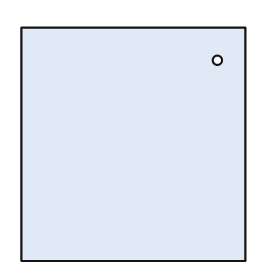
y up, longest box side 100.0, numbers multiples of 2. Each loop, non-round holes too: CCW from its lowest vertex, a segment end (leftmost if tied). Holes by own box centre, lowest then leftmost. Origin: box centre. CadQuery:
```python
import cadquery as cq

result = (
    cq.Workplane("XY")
    .moveTo(-48.0, -50.0)
    .lineTo(48.0, -50.0)
    .lineTo(48.0, 50.0)
    .lineTo(-48.0, 50.0)
    .close()
    .moveTo(36.0, 36.0)
    .circle(2.0)
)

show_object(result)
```